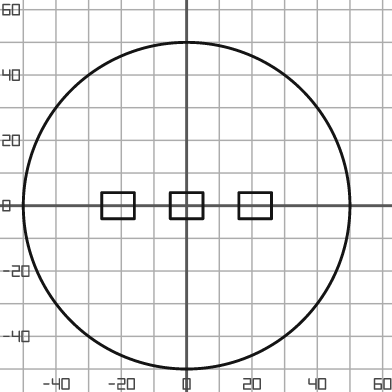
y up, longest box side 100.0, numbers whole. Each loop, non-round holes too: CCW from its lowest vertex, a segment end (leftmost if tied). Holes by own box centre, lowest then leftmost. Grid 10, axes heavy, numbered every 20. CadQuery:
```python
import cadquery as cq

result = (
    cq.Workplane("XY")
    .moveTo(0.0, 0.0)
    .circle(50.0)
    .moveTo(-26.0, -4.0)
    .lineTo(-16.0, -4.0)
    .lineTo(-16.0, 4.0)
    .lineTo(-26.0, 4.0)
    .close()
    .moveTo(-5.0, -4.0)
    .lineTo(5.0, -4.0)
    .lineTo(5.0, 4.0)
    .lineTo(-5.0, 4.0)
    .close()
    .moveTo(16.0, -4.0)
    .lineTo(26.0, -4.0)
    .lineTo(26.0, 4.0)
    .lineTo(16.0, 4.0)
    .close()
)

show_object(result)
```